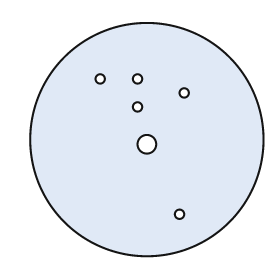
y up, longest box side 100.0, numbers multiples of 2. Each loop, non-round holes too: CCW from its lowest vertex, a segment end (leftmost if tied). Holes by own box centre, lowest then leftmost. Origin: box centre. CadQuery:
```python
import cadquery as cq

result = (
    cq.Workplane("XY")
    .moveTo(0.0, 0.0)
    .circle(50.0)
    .moveTo(14.0, -32.0)
    .circle(2.0)
    .moveTo(0.0, -2.0)
    .circle(4.0)
    .moveTo(-4.0, 14.0)
    .circle(2.0)
    .moveTo(16.0, 20.0)
    .circle(2.0)
    .moveTo(-20.0, 26.0)
    .circle(2.0)
    .moveTo(-4.0, 26.0)
    .circle(2.0)
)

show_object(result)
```